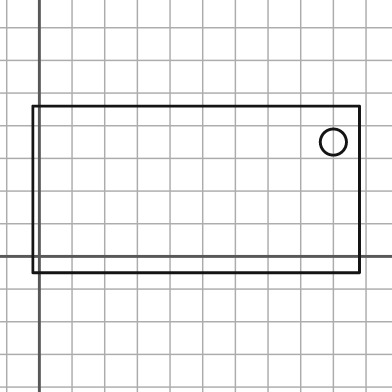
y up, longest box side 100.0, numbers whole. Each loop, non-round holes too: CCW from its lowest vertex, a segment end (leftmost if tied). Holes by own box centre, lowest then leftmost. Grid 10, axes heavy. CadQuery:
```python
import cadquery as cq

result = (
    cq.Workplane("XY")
    .moveTo(-2.0, -5.0)
    .lineTo(98.0, -5.0)
    .lineTo(98.0, 46.0)
    .lineTo(-2.0, 46.0)
    .close()
    .moveTo(90.0, 35.0)
    .circle(4.0)
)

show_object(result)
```